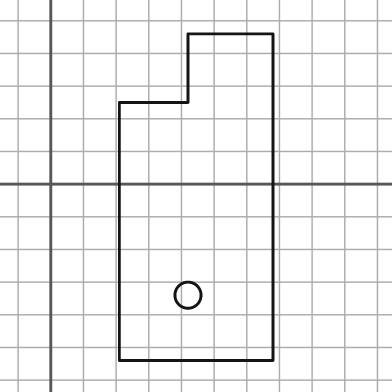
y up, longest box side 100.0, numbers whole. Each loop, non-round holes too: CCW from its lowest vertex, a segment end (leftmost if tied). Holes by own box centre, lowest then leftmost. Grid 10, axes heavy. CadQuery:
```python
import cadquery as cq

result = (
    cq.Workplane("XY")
    .moveTo(21.0, -54.0)
    .lineTo(68.0, -54.0)
    .lineTo(68.0, 46.0)
    .lineTo(42.0, 46.0)
    .lineTo(42.0, 25.0)
    .lineTo(21.0, 25.0)
    .close()
    .moveTo(42.0, -34.0)
    .circle(4.0)
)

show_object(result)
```